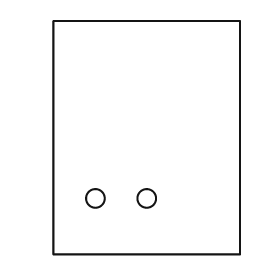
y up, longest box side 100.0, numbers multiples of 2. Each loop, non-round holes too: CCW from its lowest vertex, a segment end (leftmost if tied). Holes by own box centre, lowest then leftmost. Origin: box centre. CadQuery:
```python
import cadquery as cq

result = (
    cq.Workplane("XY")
    .moveTo(-40.0, -50.0)
    .lineTo(40.0, -50.0)
    .lineTo(40.0, 50.0)
    .lineTo(-40.0, 50.0)
    .close()
    .moveTo(-22.0, -26.0)
    .circle(4.0)
    .moveTo(0.0, -26.0)
    .circle(4.0)
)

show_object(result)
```